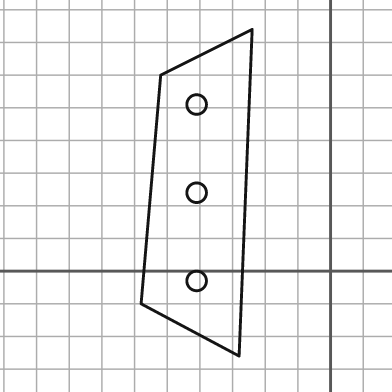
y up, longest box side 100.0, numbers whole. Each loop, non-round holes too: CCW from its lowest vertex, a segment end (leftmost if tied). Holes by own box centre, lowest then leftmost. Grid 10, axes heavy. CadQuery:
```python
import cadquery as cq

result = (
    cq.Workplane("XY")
    .moveTo(-28.0, -26.0)
    .lineTo(-24.0, 74.0)
    .lineTo(-52.0, 60.0)
    .lineTo(-58.0, -10.0)
    .close()
    .moveTo(-41.0, -3.0)
    .circle(3.0)
    .moveTo(-41.0, 24.0)
    .circle(3.0)
    .moveTo(-41.0, 51.0)
    .circle(3.0)
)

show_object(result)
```